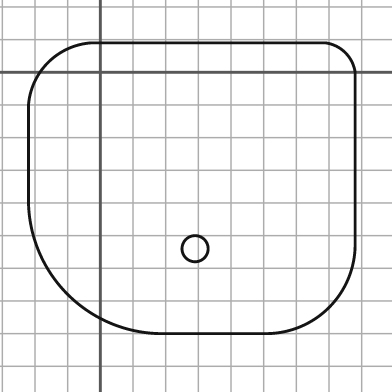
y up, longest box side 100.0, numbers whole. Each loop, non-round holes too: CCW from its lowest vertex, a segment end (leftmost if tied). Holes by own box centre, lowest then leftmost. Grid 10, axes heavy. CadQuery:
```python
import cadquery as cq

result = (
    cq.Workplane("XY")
    .moveTo(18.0, -80.0)
    .lineTo(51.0, -80.0)
    .threePointArc((70.0, -72.0), (78.0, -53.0))
    .lineTo(78.0, 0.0)
    .threePointArc((75.0, 6.0), (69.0, 9.0))
    .lineTo(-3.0, 9.0)
    .threePointArc((-16.0, 3.0), (-22.0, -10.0))
    .lineTo(-22.0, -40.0)
    .threePointArc((-10.0, -68.0), (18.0, -80.0))
    .close()
    .moveTo(29.0, -54.0)
    .circle(4.0)
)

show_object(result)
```